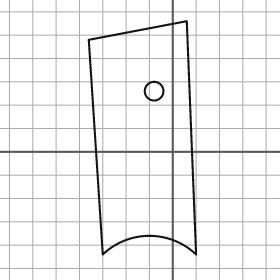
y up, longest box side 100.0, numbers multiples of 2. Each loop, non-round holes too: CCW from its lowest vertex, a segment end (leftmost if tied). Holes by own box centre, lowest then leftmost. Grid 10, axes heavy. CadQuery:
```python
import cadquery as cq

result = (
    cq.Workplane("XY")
    .moveTo(-30.0, -44.0)
    .threePointArc((-10.0, -36.0), (10.0, -44.0))
    .lineTo(6.0, 56.0)
    .lineTo(-36.0, 48.0)
    .close()
    .moveTo(-8.0, 26.0)
    .circle(4.0)
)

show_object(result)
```